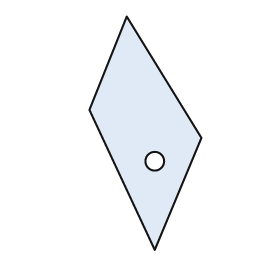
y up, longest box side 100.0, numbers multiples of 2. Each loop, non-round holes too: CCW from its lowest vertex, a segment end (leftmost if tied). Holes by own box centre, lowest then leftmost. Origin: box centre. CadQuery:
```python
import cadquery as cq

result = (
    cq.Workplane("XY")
    .moveTo(4.0, -50.0)
    .lineTo(24.0, -2.0)
    .lineTo(-8.0, 50.0)
    .lineTo(-24.0, 10.0)
    .close()
    .moveTo(4.0, -12.0)
    .circle(4.0)
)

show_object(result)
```